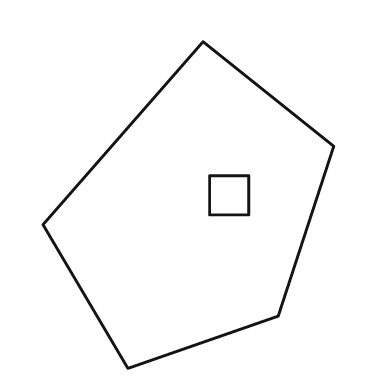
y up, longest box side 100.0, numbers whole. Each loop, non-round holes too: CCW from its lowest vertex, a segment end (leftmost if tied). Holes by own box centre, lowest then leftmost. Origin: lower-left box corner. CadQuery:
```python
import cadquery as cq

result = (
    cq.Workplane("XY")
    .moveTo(26.0, 0.0)
    .lineTo(72.0, 16.0)
    .lineTo(89.0, 68.0)
    .lineTo(49.0, 100.0)
    .lineTo(0.0, 44.0)
    .close()
    .moveTo(51.0, 47.0)
    .lineTo(63.0, 47.0)
    .lineTo(63.0, 59.0)
    .lineTo(51.0, 59.0)
    .close()
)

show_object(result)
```